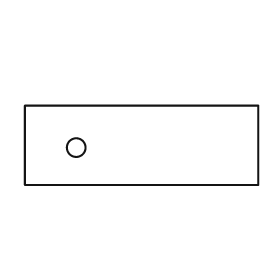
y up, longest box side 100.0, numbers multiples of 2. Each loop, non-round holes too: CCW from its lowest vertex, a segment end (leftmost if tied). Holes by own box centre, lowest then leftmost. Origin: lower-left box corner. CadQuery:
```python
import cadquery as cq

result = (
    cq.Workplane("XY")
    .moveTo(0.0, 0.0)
    .lineTo(100.0, 0.0)
    .lineTo(100.0, 34.0)
    .lineTo(0.0, 34.0)
    .close()
    .moveTo(22.0, 16.0)
    .circle(4.0)
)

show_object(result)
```